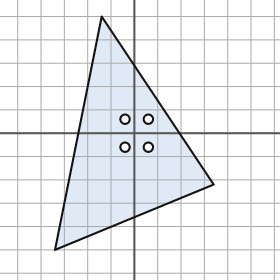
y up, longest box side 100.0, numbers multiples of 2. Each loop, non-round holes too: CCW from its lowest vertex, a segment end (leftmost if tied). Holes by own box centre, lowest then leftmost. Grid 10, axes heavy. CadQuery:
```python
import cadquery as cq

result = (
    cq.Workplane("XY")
    .moveTo(-34.0, -50.0)
    .lineTo(34.0, -22.0)
    .lineTo(-14.0, 50.0)
    .close()
    .moveTo(-4.0, -6.0)
    .circle(2.0)
    .moveTo(6.0, -6.0)
    .circle(2.0)
    .moveTo(-4.0, 6.0)
    .circle(2.0)
    .moveTo(6.0, 6.0)
    .circle(2.0)
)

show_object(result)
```